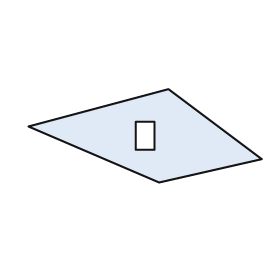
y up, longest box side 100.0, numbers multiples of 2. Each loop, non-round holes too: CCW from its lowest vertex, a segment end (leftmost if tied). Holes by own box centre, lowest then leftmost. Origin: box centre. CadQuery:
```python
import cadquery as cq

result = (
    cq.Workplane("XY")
    .moveTo(6.0, -20.0)
    .lineTo(50.0, -10.0)
    .lineTo(10.0, 20.0)
    .lineTo(-50.0, 4.0)
    .close()
    .moveTo(-4.0, -6.0)
    .lineTo(4.0, -6.0)
    .lineTo(4.0, 6.0)
    .lineTo(-4.0, 6.0)
    .close()
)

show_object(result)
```